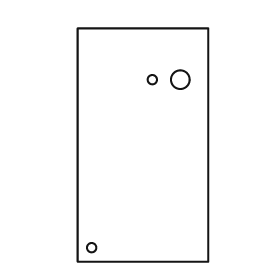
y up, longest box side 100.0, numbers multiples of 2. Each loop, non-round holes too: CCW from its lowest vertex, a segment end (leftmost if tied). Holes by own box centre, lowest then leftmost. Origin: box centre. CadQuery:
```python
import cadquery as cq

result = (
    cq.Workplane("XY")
    .moveTo(-28.0, -50.0)
    .lineTo(28.0, -50.0)
    .lineTo(28.0, 50.0)
    .lineTo(-28.0, 50.0)
    .close()
    .moveTo(-22.0, -44.0)
    .circle(2.0)
    .moveTo(4.0, 28.0)
    .circle(2.0)
    .moveTo(16.0, 28.0)
    .circle(4.0)
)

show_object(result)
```